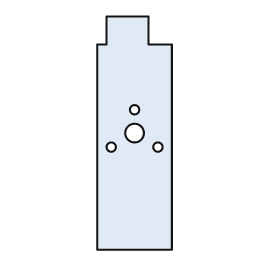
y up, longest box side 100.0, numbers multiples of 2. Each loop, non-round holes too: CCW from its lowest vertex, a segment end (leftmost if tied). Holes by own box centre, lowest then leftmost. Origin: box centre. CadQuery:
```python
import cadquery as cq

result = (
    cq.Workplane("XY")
    .moveTo(-16.0, -50.0)
    .lineTo(16.0, -50.0)
    .lineTo(16.0, 38.0)
    .lineTo(6.0, 38.0)
    .lineTo(6.0, 50.0)
    .lineTo(-12.0, 50.0)
    .lineTo(-12.0, 38.0)
    .lineTo(-16.0, 38.0)
    .close()
    .moveTo(-10.0, -6.0)
    .circle(2.0)
    .moveTo(10.0, -6.0)
    .circle(2.0)
    .moveTo(0.0, 0.0)
    .circle(4.0)
    .moveTo(0.0, 10.0)
    .circle(2.0)
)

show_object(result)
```